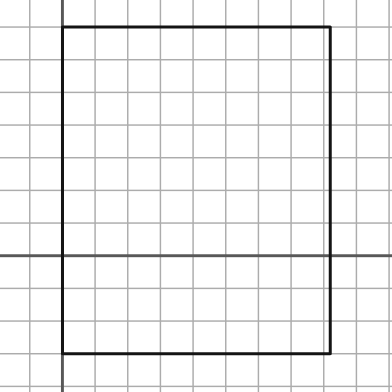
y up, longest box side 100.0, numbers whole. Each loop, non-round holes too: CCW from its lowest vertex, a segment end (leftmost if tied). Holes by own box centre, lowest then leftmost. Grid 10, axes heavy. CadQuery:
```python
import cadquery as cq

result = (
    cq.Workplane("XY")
    .moveTo(0.0, -30.0)
    .lineTo(82.0, -30.0)
    .lineTo(82.0, 70.0)
    .lineTo(0.0, 70.0)
    .close()
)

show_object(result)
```